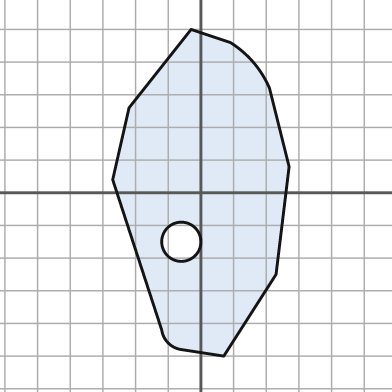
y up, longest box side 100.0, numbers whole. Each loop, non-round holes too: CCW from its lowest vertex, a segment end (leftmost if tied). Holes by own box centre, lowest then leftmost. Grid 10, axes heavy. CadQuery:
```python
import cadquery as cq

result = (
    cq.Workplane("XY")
    .moveTo(7.0, -50.0)
    .lineTo(23.0, -25.0)
    .lineTo(27.0, 8.0)
    .lineTo(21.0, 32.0)
    .threePointArc((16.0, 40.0), (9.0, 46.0))
    .lineTo(-3.0, 50.0)
    .lineTo(-22.0, 26.0)
    .lineTo(-27.0, 4.0)
    .lineTo(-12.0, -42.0)
    .threePointArc((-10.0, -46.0), (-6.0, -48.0))
    .close()
    .moveTo(-6.0, -15.0)
    .circle(6.0)
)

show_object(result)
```